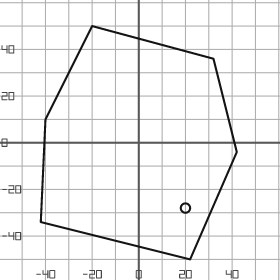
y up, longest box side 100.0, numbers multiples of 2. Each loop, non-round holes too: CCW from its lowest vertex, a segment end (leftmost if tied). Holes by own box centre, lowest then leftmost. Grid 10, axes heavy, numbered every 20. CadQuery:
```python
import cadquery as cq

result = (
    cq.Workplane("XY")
    .moveTo(22.0, -50.0)
    .lineTo(42.0, -4.0)
    .lineTo(32.0, 36.0)
    .lineTo(-20.0, 50.0)
    .lineTo(-40.0, 10.0)
    .lineTo(-42.0, -34.0)
    .close()
    .moveTo(20.0, -28.0)
    .circle(2.0)
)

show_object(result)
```